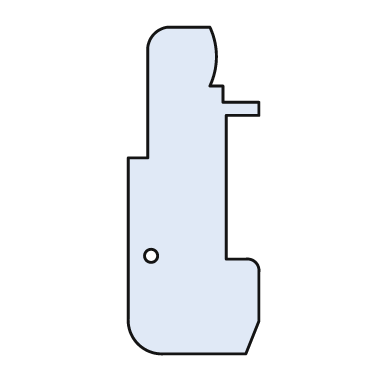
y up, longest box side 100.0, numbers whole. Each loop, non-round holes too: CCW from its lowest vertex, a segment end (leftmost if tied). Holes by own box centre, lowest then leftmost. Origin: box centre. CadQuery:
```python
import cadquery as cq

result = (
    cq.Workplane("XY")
    .moveTo(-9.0, -50.0)
    .lineTo(16.0, -50.0)
    .lineTo(20.0, -40.0)
    .lineTo(20.0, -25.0)
    .threePointArc((19.0, -22.0), (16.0, -21.0))
    .lineTo(10.0, -21.0)
    .lineTo(10.0, 23.0)
    .lineTo(20.0, 23.0)
    .lineTo(20.0, 27.0)
    .lineTo(9.0, 27.0)
    .lineTo(9.0, 32.0)
    .lineTo(5.0, 32.0)
    .threePointArc((7.0, 41.0), (5.0, 50.0))
    .lineTo(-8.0, 50.0)
    .threePointArc((-12.0, 48.0), (-14.0, 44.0))
    .lineTo(-14.0, 10.0)
    .lineTo(-20.0, 10.0)
    .lineTo(-20.0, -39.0)
    .threePointArc((-17.0, -47.0), (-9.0, -50.0))
    .close()
    .moveTo(-13.0, -20.0)
    .circle(2.0)
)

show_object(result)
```